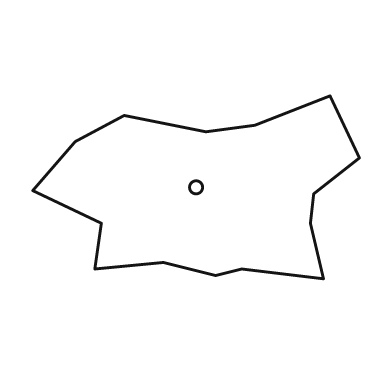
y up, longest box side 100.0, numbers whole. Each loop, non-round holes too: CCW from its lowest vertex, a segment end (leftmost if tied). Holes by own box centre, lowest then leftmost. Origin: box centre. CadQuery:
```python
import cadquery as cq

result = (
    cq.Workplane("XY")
    .moveTo(39.0, -28.0)
    .lineTo(35.0, -11.0)
    .lineTo(36.0, -2.0)
    .lineTo(50.0, 9.0)
    .lineTo(41.0, 28.0)
    .lineTo(18.0, 19.0)
    .lineTo(3.0, 17.0)
    .lineTo(-22.0, 22.0)
    .lineTo(-37.0, 14.0)
    .lineTo(-50.0, -1.0)
    .lineTo(-29.0, -11.0)
    .lineTo(-31.0, -25.0)
    .lineTo(-10.0, -23.0)
    .lineTo(6.0, -27.0)
    .lineTo(14.0, -25.0)
    .close()
    .moveTo(0.0, 0.0)
    .circle(2.0)
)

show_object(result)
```